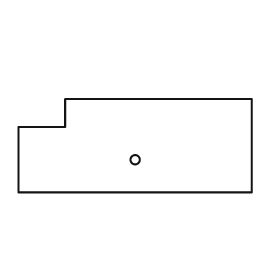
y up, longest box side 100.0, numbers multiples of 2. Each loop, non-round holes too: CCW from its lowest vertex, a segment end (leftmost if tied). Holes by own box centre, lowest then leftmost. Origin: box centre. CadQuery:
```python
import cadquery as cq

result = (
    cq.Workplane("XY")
    .moveTo(-50.0, -20.0)
    .lineTo(50.0, -20.0)
    .lineTo(50.0, 20.0)
    .lineTo(-30.0, 20.0)
    .lineTo(-30.0, 8.0)
    .lineTo(-50.0, 8.0)
    .close()
    .moveTo(0.0, -6.0)
    .circle(2.0)
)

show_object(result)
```